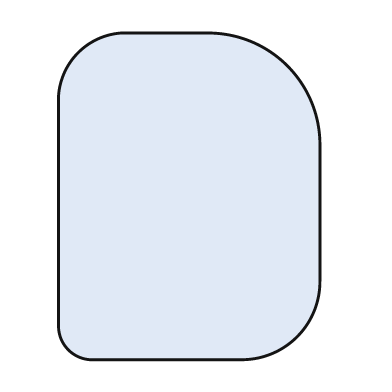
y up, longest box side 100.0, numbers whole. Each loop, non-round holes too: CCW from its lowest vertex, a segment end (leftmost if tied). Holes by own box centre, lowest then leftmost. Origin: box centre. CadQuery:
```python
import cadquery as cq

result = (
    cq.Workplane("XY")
    .moveTo(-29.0, -50.0)
    .lineTo(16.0, -50.0)
    .threePointArc((33.0, -43.0), (40.0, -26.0))
    .lineTo(40.0, 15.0)
    .threePointArc((30.0, 40.0), (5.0, 50.0))
    .lineTo(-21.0, 50.0)
    .threePointArc((-34.0, 44.0), (-40.0, 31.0))
    .lineTo(-40.0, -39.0)
    .threePointArc((-37.0, -47.0), (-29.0, -50.0))
    .close()
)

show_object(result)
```